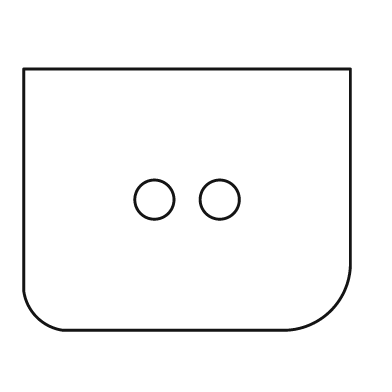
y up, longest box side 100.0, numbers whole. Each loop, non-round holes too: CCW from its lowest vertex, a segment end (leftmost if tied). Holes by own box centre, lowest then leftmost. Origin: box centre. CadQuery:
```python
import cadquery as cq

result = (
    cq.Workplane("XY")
    .moveTo(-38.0, -40.0)
    .lineTo(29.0, -40.0)
    .threePointArc((44.0, -34.0), (50.0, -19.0))
    .lineTo(50.0, 40.0)
    .lineTo(-50.0, 40.0)
    .lineTo(-50.0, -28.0)
    .threePointArc((-46.0, -36.0), (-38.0, -40.0))
    .close()
    .moveTo(-10.0, 0.0)
    .circle(6.0)
    .moveTo(10.0, 0.0)
    .circle(6.0)
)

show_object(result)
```